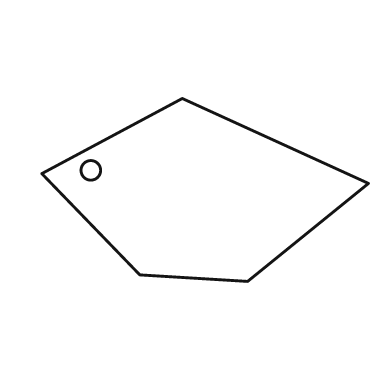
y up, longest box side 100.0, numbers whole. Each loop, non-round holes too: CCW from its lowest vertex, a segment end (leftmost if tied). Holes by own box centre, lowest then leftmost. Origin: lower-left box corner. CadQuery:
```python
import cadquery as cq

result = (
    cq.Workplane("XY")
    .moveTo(63.0, 0.0)
    .lineTo(100.0, 30.0)
    .lineTo(43.0, 56.0)
    .lineTo(0.0, 33.0)
    .lineTo(30.0, 2.0)
    .close()
    .moveTo(15.0, 34.0)
    .circle(3.0)
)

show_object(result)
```